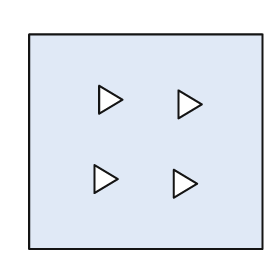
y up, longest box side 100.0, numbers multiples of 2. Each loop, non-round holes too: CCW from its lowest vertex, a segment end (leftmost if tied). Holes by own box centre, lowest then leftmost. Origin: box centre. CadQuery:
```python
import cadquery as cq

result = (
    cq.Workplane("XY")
    .moveTo(-50.0, -46.0)
    .lineTo(50.0, -46.0)
    .lineTo(50.0, 46.0)
    .lineTo(-50.0, 46.0)
    .close()
    .moveTo(12.0, -24.0)
    .lineTo(22.0, -18.0)
    .lineTo(12.0, -12.0)
    .close()
    .moveTo(-22.0, -22.0)
    .lineTo(-12.0, -16.0)
    .lineTo(-22.0, -10.0)
    .close()
    .moveTo(14.0, 10.0)
    .lineTo(24.0, 16.0)
    .lineTo(14.0, 22.0)
    .close()
    .moveTo(-20.0, 12.0)
    .lineTo(-10.0, 18.0)
    .lineTo(-20.0, 24.0)
    .close()
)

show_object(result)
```